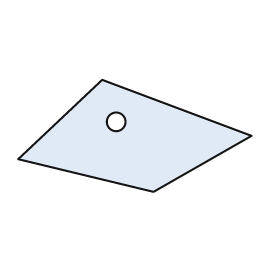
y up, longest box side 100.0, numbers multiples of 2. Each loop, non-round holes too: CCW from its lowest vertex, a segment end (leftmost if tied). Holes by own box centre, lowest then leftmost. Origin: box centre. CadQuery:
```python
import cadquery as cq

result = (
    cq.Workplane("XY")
    .moveTo(8.0, -24.0)
    .lineTo(50.0, 0.0)
    .lineTo(-14.0, 24.0)
    .lineTo(-50.0, -10.0)
    .close()
    .moveTo(-8.0, 6.0)
    .circle(4.0)
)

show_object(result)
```